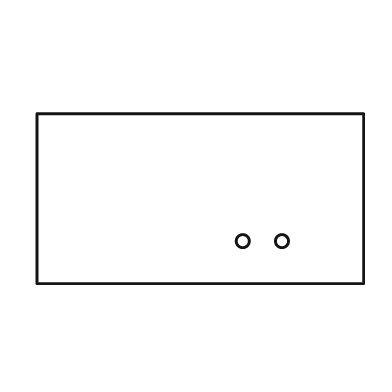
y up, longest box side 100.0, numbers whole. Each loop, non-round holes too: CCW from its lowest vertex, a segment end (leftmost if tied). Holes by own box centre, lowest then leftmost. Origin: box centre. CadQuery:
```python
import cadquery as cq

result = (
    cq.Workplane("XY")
    .moveTo(-50.0, -26.0)
    .lineTo(50.0, -26.0)
    .lineTo(50.0, 26.0)
    .lineTo(-50.0, 26.0)
    .close()
    .moveTo(13.0, -13.0)
    .circle(2.0)
    .moveTo(25.0, -13.0)
    .circle(2.0)
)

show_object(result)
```